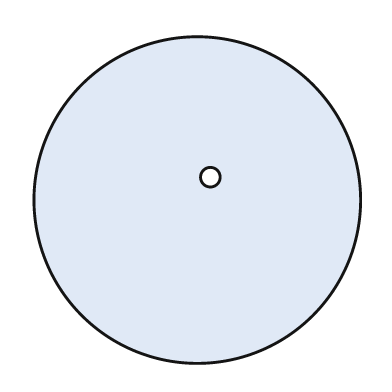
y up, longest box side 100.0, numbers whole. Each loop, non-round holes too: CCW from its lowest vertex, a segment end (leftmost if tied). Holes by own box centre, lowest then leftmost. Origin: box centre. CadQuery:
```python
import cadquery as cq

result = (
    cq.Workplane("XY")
    .moveTo(0.0, 0.0)
    .circle(50.0)
    .moveTo(4.0, 7.0)
    .circle(3.0)
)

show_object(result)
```